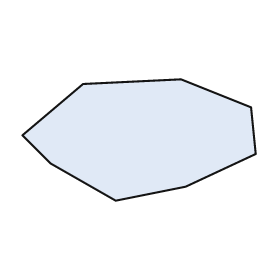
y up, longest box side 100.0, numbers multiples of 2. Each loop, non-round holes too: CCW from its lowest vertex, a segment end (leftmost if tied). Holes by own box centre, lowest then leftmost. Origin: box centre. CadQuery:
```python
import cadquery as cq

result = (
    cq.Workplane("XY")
    .moveTo(-10.0, -26.0)
    .lineTo(20.0, -20.0)
    .lineTo(50.0, -6.0)
    .lineTo(48.0, 14.0)
    .lineTo(18.0, 26.0)
    .lineTo(-24.0, 24.0)
    .lineTo(-50.0, 2.0)
    .lineTo(-38.0, -10.0)
    .close()
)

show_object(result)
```